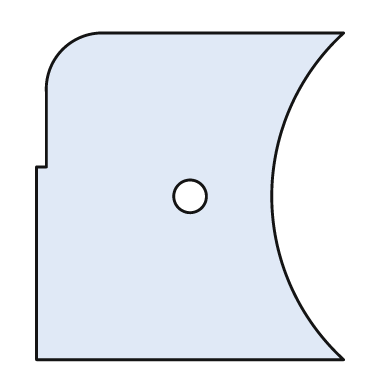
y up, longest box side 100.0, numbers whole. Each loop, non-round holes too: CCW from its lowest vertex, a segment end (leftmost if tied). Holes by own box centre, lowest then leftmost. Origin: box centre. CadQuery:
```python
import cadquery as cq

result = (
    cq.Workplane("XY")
    .moveTo(-47.0, -50.0)
    .lineTo(47.0, -50.0)
    .threePointArc((25.0, 0.0), (47.0, 50.0))
    .lineTo(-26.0, 50.0)
    .threePointArc((-39.0, 45.0), (-44.0, 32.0))
    .lineTo(-44.0, 9.0)
    .lineTo(-47.0, 9.0)
    .close()
    .moveTo(0.0, 0.0)
    .circle(5.0)
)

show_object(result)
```